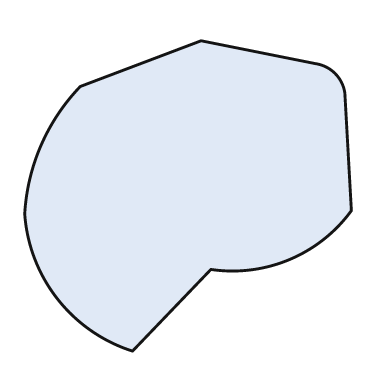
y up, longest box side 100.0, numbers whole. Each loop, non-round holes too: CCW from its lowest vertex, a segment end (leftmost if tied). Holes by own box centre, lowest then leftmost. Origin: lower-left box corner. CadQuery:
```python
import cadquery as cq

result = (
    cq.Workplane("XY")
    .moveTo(33.0, 0.0)
    .lineTo(57.0, 25.0)
    .threePointArc((81.0, 28.0), (100.0, 43.0))
    .lineTo(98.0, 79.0)
    .threePointArc((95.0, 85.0), (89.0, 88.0))
    .lineTo(54.0, 95.0)
    .lineTo(17.0, 81.0)
    .threePointArc((5.0, 63.0), (0.0, 42.0))
    .threePointArc((10.0, 16.0), (33.0, 0.0))
    .close()
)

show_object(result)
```